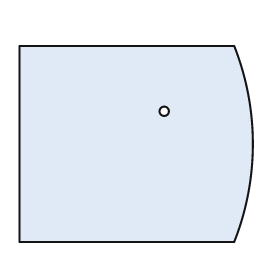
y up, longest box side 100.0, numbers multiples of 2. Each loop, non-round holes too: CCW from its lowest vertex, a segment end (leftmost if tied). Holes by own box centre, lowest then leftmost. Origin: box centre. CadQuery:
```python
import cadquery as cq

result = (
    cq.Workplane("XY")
    .moveTo(-50.0, -42.0)
    .lineTo(42.0, -42.0)
    .threePointArc((50.0, 0.0), (42.0, 42.0))
    .lineTo(-50.0, 42.0)
    .close()
    .moveTo(12.0, 14.0)
    .circle(2.0)
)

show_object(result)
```